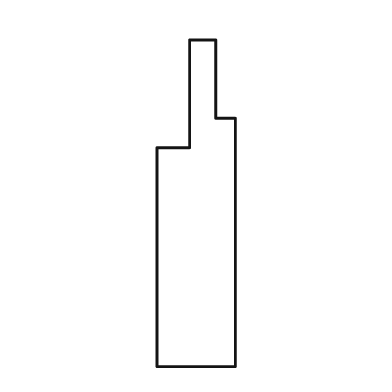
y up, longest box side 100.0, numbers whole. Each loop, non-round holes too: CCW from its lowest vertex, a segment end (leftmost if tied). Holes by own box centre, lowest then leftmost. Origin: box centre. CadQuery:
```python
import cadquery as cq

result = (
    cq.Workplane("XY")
    .moveTo(-12.0, -50.0)
    .lineTo(12.0, -50.0)
    .lineTo(12.0, 26.0)
    .lineTo(6.0, 26.0)
    .lineTo(6.0, 50.0)
    .lineTo(-2.0, 50.0)
    .lineTo(-2.0, 17.0)
    .lineTo(-12.0, 17.0)
    .close()
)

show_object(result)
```